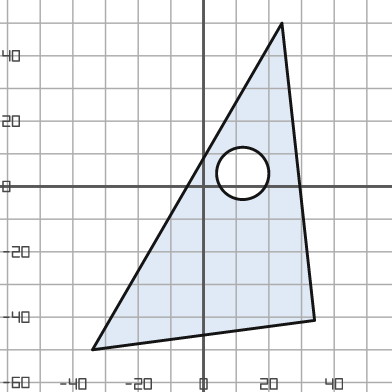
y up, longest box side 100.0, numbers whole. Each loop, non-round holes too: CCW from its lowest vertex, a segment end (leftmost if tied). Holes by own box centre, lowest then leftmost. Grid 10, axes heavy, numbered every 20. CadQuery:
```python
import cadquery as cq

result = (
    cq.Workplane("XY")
    .moveTo(-34.0, -50.0)
    .lineTo(34.0, -41.0)
    .lineTo(24.0, 50.0)
    .close()
    .moveTo(12.0, 4.0)
    .circle(8.0)
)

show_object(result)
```